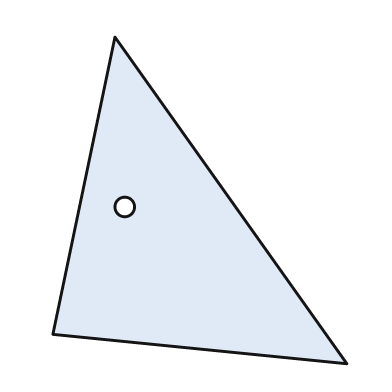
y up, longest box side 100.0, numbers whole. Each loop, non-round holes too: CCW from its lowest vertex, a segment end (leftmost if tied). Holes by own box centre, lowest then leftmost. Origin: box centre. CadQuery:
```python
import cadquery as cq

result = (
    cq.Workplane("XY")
    .moveTo(45.0, -50.0)
    .lineTo(-26.0, 50.0)
    .lineTo(-45.0, -41.0)
    .close()
    .moveTo(-23.0, -2.0)
    .circle(3.0)
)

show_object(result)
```